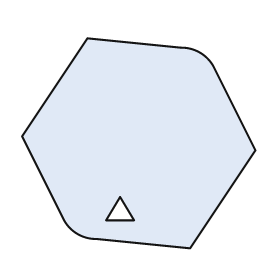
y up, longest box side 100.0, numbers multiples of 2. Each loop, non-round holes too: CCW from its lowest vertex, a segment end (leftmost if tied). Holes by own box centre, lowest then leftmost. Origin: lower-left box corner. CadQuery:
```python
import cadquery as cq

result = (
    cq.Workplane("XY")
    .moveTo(72.0, 0.0)
    .lineTo(100.0, 42.0)
    .lineTo(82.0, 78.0)
    .threePointArc((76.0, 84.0), (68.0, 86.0))
    .lineTo(28.0, 90.0)
    .lineTo(0.0, 48.0)
    .lineTo(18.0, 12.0)
    .threePointArc((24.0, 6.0), (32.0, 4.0))
    .close()
    .moveTo(36.0, 12.0)
    .lineTo(48.0, 12.0)
    .lineTo(42.0, 22.0)
    .close()
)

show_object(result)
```